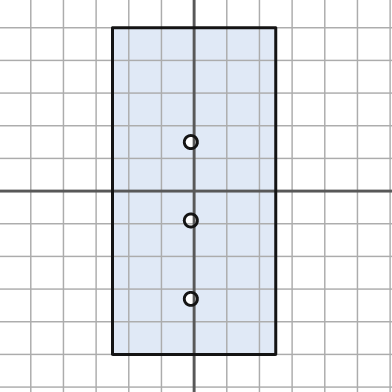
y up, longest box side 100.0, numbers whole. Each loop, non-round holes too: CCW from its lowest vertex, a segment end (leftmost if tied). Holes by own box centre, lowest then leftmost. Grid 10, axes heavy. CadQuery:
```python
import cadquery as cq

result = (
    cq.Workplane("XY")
    .moveTo(-25.0, -50.0)
    .lineTo(25.0, -50.0)
    .lineTo(25.0, 50.0)
    .lineTo(-25.0, 50.0)
    .close()
    .moveTo(-1.0, -33.0)
    .circle(2.0)
    .moveTo(-1.0, -9.0)
    .circle(2.0)
    .moveTo(-1.0, 15.0)
    .circle(2.0)
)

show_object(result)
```